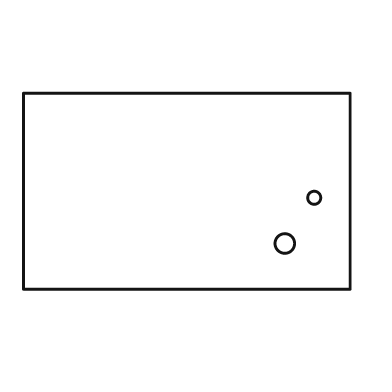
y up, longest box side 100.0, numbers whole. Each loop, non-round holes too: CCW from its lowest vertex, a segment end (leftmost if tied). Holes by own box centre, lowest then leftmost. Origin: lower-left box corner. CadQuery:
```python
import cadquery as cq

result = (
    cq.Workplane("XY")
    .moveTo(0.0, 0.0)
    .lineTo(100.0, 0.0)
    .lineTo(100.0, 60.0)
    .lineTo(0.0, 60.0)
    .close()
    .moveTo(80.0, 14.0)
    .circle(3.0)
    .moveTo(89.0, 28.0)
    .circle(2.0)
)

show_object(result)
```